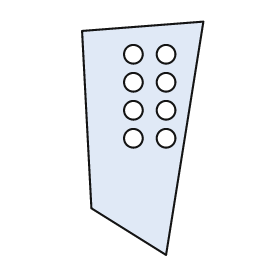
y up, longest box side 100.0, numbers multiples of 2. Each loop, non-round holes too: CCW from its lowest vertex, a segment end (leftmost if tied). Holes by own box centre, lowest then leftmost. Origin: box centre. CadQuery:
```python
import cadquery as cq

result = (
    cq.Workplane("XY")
    .moveTo(10.0, -50.0)
    .lineTo(26.0, 50.0)
    .lineTo(-26.0, 46.0)
    .lineTo(-22.0, -30.0)
    .close()
    .moveTo(-4.0, 0.0)
    .circle(4.0)
    .moveTo(10.0, 0.0)
    .circle(4.0)
    .moveTo(-4.0, 12.0)
    .circle(4.0)
    .moveTo(10.0, 12.0)
    .circle(4.0)
    .moveTo(-4.0, 24.0)
    .circle(4.0)
    .moveTo(10.0, 24.0)
    .circle(4.0)
    .moveTo(-4.0, 36.0)
    .circle(4.0)
    .moveTo(10.0, 36.0)
    .circle(4.0)
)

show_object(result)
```